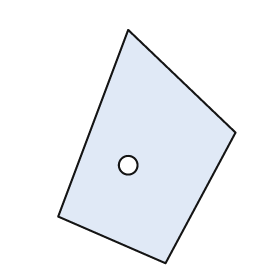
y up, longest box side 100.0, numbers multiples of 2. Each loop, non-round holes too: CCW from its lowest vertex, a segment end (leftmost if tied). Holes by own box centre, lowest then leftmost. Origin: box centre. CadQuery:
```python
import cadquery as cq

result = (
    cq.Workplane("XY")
    .moveTo(8.0, -50.0)
    .lineTo(38.0, 6.0)
    .lineTo(-8.0, 50.0)
    .lineTo(-38.0, -30.0)
    .close()
    .moveTo(-8.0, -8.0)
    .circle(4.0)
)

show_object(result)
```